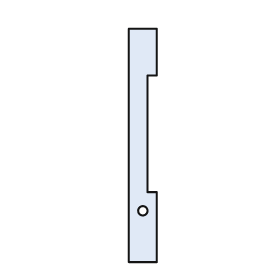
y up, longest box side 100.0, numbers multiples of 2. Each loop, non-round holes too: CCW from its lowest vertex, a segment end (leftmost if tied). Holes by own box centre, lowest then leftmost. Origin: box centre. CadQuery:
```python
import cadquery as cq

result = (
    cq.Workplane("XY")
    .moveTo(-6.0, -50.0)
    .lineTo(6.0, -50.0)
    .lineTo(6.0, -20.0)
    .lineTo(2.0, -20.0)
    .lineTo(2.0, 30.0)
    .lineTo(6.0, 30.0)
    .lineTo(6.0, 50.0)
    .lineTo(-6.0, 50.0)
    .close()
    .moveTo(0.0, -28.0)
    .circle(2.0)
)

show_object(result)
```